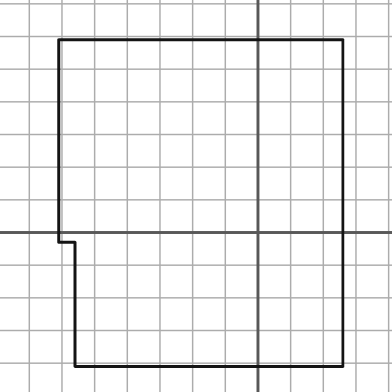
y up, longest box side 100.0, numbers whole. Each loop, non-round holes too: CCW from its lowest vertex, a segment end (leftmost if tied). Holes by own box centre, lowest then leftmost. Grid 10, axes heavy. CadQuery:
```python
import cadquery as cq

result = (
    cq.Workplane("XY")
    .moveTo(-56.0, -41.0)
    .lineTo(26.0, -41.0)
    .lineTo(26.0, 59.0)
    .lineTo(-61.0, 59.0)
    .lineTo(-61.0, -3.0)
    .lineTo(-56.0, -3.0)
    .close()
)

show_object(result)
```